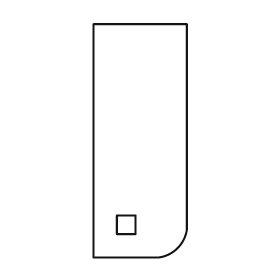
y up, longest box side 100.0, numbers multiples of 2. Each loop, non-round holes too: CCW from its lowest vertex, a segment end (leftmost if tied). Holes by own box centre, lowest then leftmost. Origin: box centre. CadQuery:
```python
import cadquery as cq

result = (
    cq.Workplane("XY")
    .moveTo(-20.0, -50.0)
    .lineTo(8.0, -50.0)
    .threePointArc((16.0, -46.0), (20.0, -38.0))
    .lineTo(20.0, 50.0)
    .lineTo(-20.0, 50.0)
    .close()
    .moveTo(-10.0, -40.0)
    .lineTo(-2.0, -40.0)
    .lineTo(-2.0, -32.0)
    .lineTo(-10.0, -32.0)
    .close()
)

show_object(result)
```